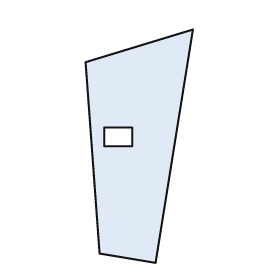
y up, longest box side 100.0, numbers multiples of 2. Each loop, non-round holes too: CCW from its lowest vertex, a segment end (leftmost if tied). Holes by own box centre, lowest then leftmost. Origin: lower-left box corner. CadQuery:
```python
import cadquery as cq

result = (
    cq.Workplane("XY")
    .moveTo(30.0, 0.0)
    .lineTo(46.0, 100.0)
    .lineTo(0.0, 86.0)
    .lineTo(6.0, 4.0)
    .close()
    .moveTo(8.0, 50.0)
    .lineTo(20.0, 50.0)
    .lineTo(20.0, 58.0)
    .lineTo(8.0, 58.0)
    .close()
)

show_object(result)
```